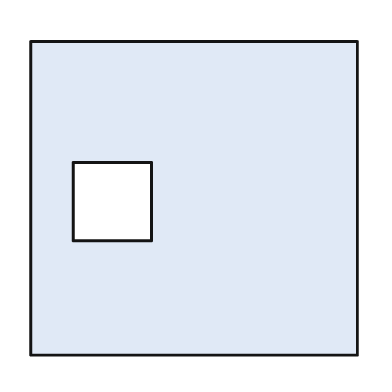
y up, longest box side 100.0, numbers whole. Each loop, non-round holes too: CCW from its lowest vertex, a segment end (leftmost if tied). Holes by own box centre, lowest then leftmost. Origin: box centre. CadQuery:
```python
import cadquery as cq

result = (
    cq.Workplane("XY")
    .moveTo(-50.0, -48.0)
    .lineTo(50.0, -48.0)
    .lineTo(50.0, 48.0)
    .lineTo(-50.0, 48.0)
    .close()
    .moveTo(-37.0, -13.0)
    .lineTo(-13.0, -13.0)
    .lineTo(-13.0, 11.0)
    .lineTo(-37.0, 11.0)
    .close()
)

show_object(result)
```